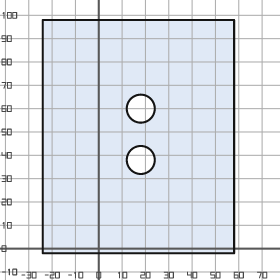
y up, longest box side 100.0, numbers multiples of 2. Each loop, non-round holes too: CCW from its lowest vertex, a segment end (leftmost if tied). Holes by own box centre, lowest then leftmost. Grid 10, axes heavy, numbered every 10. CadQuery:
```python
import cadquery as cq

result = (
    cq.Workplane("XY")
    .moveTo(-24.0, -2.0)
    .lineTo(58.0, -2.0)
    .lineTo(58.0, 98.0)
    .lineTo(-24.0, 98.0)
    .close()
    .moveTo(18.0, 38.0)
    .circle(6.0)
    .moveTo(18.0, 60.0)
    .circle(6.0)
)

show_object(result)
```